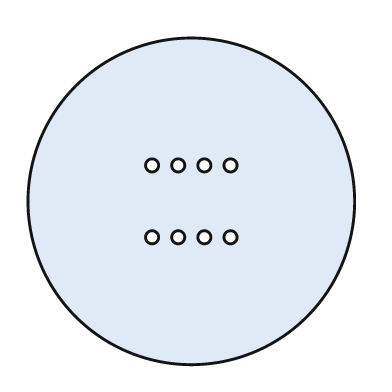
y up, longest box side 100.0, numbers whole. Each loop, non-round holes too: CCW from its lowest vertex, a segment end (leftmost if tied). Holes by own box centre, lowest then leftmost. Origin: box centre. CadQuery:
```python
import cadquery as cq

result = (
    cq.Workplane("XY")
    .moveTo(0.0, 0.0)
    .circle(50.0)
    .moveTo(-12.0, -11.0)
    .circle(2.0)
    .moveTo(-4.0, -11.0)
    .circle(2.0)
    .moveTo(4.0, -11.0)
    .circle(2.0)
    .moveTo(12.0, -11.0)
    .circle(2.0)
    .moveTo(-12.0, 11.0)
    .circle(2.0)
    .moveTo(-4.0, 11.0)
    .circle(2.0)
    .moveTo(4.0, 11.0)
    .circle(2.0)
    .moveTo(12.0, 11.0)
    .circle(2.0)
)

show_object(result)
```